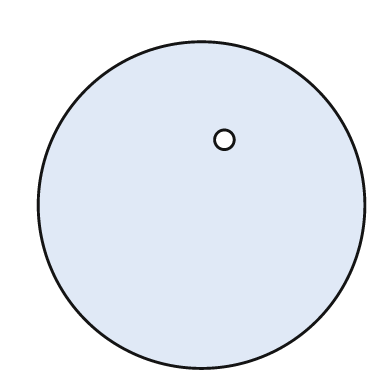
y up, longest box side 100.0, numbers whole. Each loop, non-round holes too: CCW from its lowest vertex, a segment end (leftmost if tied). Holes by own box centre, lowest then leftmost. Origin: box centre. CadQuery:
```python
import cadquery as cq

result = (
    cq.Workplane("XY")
    .moveTo(0.0, 0.0)
    .circle(50.0)
    .moveTo(7.0, 20.0)
    .circle(3.0)
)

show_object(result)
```